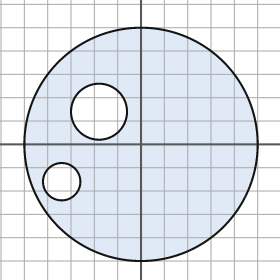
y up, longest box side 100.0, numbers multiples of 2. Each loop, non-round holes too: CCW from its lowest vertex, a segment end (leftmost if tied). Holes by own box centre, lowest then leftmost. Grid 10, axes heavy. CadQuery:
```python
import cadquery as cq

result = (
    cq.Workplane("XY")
    .moveTo(0.0, 0.0)
    .circle(50.0)
    .moveTo(-34.0, -16.0)
    .circle(8.0)
    .moveTo(-18.0, 14.0)
    .circle(12.0)
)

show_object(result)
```